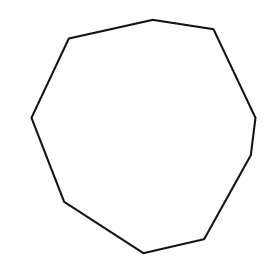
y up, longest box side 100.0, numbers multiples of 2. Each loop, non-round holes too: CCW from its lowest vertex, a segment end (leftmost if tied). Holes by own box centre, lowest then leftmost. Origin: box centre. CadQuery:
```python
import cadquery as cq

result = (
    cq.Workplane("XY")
    .moveTo(0.0, -50.0)
    .lineTo(26.0, -44.0)
    .lineTo(46.0, -8.0)
    .lineTo(48.0, 8.0)
    .lineTo(30.0, 46.0)
    .lineTo(4.0, 50.0)
    .lineTo(-32.0, 42.0)
    .lineTo(-48.0, 8.0)
    .lineTo(-34.0, -28.0)
    .close()
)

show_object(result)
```